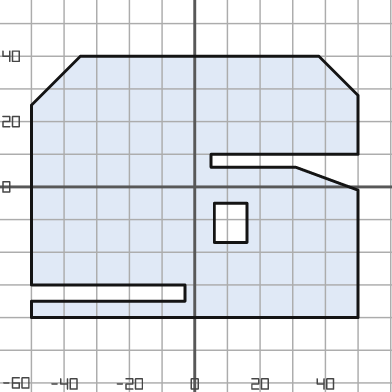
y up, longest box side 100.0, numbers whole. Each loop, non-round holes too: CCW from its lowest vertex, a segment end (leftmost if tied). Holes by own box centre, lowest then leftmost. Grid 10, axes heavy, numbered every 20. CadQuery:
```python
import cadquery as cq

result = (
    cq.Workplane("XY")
    .moveTo(-50.0, -40.0)
    .lineTo(50.0, -40.0)
    .lineTo(50.0, -1.0)
    .lineTo(31.0, 6.0)
    .lineTo(5.0, 6.0)
    .lineTo(5.0, 10.0)
    .lineTo(50.0, 10.0)
    .lineTo(50.0, 28.0)
    .lineTo(38.0, 40.0)
    .lineTo(-35.0, 40.0)
    .lineTo(-50.0, 25.0)
    .lineTo(-50.0, -30.0)
    .lineTo(-3.0, -30.0)
    .lineTo(-3.0, -35.0)
    .lineTo(-50.0, -35.0)
    .close()
    .moveTo(6.0, -17.0)
    .lineTo(16.0, -17.0)
    .lineTo(16.0, -5.0)
    .lineTo(6.0, -5.0)
    .close()
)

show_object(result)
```